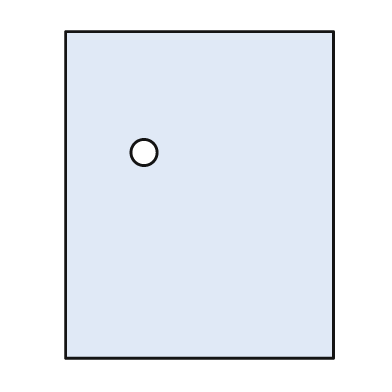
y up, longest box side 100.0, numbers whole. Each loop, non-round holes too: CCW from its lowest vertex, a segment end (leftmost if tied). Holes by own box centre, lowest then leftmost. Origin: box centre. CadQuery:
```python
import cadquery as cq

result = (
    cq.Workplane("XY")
    .moveTo(-41.0, -50.0)
    .lineTo(41.0, -50.0)
    .lineTo(41.0, 50.0)
    .lineTo(-41.0, 50.0)
    .close()
    .moveTo(-17.0, 13.0)
    .circle(4.0)
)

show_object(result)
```